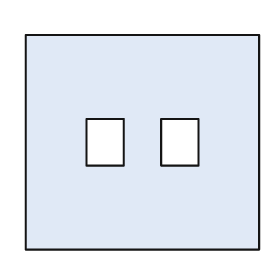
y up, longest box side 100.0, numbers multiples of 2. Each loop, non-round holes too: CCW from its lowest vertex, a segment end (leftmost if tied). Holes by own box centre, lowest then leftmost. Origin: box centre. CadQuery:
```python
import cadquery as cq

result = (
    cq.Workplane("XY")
    .moveTo(-50.0, -46.0)
    .lineTo(50.0, -46.0)
    .lineTo(50.0, 46.0)
    .lineTo(-50.0, 46.0)
    .close()
    .moveTo(-24.0, -10.0)
    .lineTo(-8.0, -10.0)
    .lineTo(-8.0, 10.0)
    .lineTo(-24.0, 10.0)
    .close()
    .moveTo(8.0, -10.0)
    .lineTo(24.0, -10.0)
    .lineTo(24.0, 10.0)
    .lineTo(8.0, 10.0)
    .close()
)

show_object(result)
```